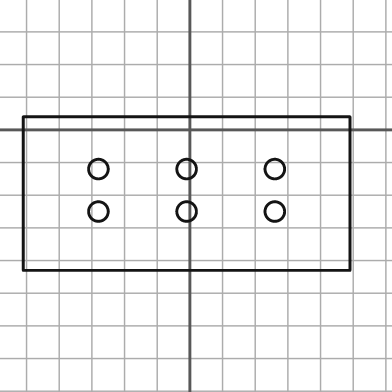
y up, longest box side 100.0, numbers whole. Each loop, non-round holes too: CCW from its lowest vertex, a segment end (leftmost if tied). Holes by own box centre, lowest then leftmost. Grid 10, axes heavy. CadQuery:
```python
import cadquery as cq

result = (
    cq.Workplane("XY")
    .moveTo(-51.0, -43.0)
    .lineTo(49.0, -43.0)
    .lineTo(49.0, 4.0)
    .lineTo(-51.0, 4.0)
    .close()
    .moveTo(-28.0, -25.0)
    .circle(3.0)
    .moveTo(-1.0, -25.0)
    .circle(3.0)
    .moveTo(26.0, -25.0)
    .circle(3.0)
    .moveTo(-28.0, -12.0)
    .circle(3.0)
    .moveTo(-1.0, -12.0)
    .circle(3.0)
    .moveTo(26.0, -12.0)
    .circle(3.0)
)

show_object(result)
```